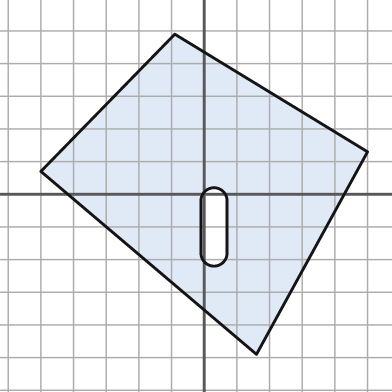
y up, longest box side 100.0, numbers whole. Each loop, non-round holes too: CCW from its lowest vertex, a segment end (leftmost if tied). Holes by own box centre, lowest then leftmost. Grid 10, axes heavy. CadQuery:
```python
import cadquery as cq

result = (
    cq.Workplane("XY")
    .moveTo(16.0, -49.0)
    .lineTo(50.0, 13.0)
    .lineTo(-9.0, 49.0)
    .lineTo(-50.0, 7.0)
    .close()
    .moveTo(-1.0, -18.0)
    .threePointArc((3.0, -22.0), (7.0, -18.0))
    .lineTo(7.0, -2.0)
    .threePointArc((3.0, 2.0), (-1.0, -2.0))
    .close()
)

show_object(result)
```